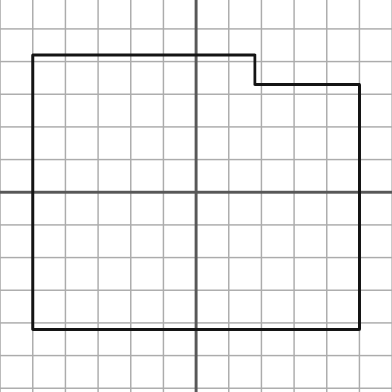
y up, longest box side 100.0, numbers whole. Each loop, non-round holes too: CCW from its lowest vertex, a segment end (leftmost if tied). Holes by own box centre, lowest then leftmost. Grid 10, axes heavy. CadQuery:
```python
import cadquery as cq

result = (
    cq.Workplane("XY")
    .moveTo(-50.0, -42.0)
    .lineTo(50.0, -42.0)
    .lineTo(50.0, 33.0)
    .lineTo(18.0, 33.0)
    .lineTo(18.0, 42.0)
    .lineTo(-50.0, 42.0)
    .close()
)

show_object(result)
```